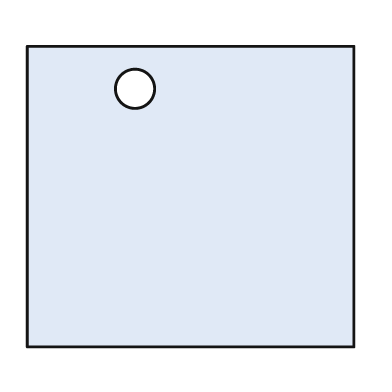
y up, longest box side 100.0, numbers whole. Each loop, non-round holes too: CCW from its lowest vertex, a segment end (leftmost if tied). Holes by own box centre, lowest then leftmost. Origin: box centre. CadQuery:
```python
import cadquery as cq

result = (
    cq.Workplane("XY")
    .moveTo(-50.0, -46.0)
    .lineTo(50.0, -46.0)
    .lineTo(50.0, 46.0)
    .lineTo(-50.0, 46.0)
    .close()
    .moveTo(-17.0, 33.0)
    .circle(6.0)
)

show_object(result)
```